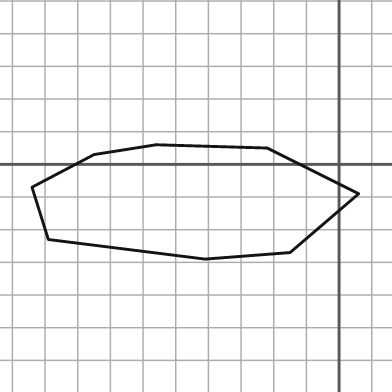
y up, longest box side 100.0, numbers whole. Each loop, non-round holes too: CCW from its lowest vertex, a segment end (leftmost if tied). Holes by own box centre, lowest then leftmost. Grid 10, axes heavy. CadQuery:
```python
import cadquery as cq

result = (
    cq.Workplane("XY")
    .moveTo(-41.0, -29.0)
    .lineTo(-15.0, -27.0)
    .lineTo(6.0, -9.0)
    .lineTo(-22.0, 5.0)
    .lineTo(-56.0, 6.0)
    .lineTo(-75.0, 3.0)
    .lineTo(-94.0, -7.0)
    .lineTo(-89.0, -23.0)
    .close()
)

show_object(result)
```